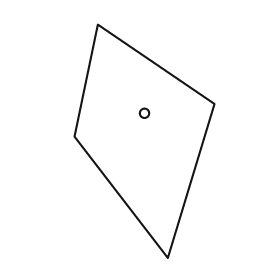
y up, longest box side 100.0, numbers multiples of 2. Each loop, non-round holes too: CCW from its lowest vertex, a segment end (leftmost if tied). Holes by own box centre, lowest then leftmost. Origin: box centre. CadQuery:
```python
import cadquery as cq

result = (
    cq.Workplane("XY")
    .moveTo(10.0, -50.0)
    .lineTo(30.0, 16.0)
    .lineTo(-20.0, 50.0)
    .lineTo(-30.0, 2.0)
    .close()
    .moveTo(0.0, 12.0)
    .circle(2.0)
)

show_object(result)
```